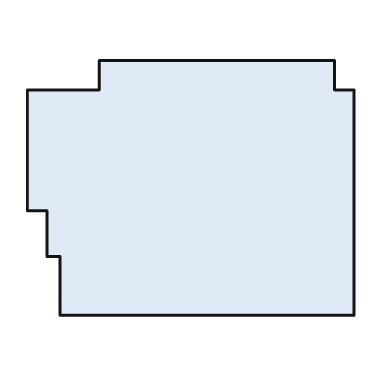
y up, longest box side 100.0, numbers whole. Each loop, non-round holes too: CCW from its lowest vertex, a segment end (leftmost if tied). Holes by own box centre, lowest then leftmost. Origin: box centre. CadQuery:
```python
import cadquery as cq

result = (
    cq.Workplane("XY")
    .moveTo(-40.0, -39.0)
    .lineTo(50.0, -39.0)
    .lineTo(50.0, 30.0)
    .lineTo(44.0, 30.0)
    .lineTo(44.0, 39.0)
    .lineTo(-28.0, 39.0)
    .lineTo(-28.0, 30.0)
    .lineTo(-50.0, 30.0)
    .lineTo(-50.0, -7.0)
    .lineTo(-44.0, -7.0)
    .lineTo(-44.0, -21.0)
    .lineTo(-40.0, -21.0)
    .close()
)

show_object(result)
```